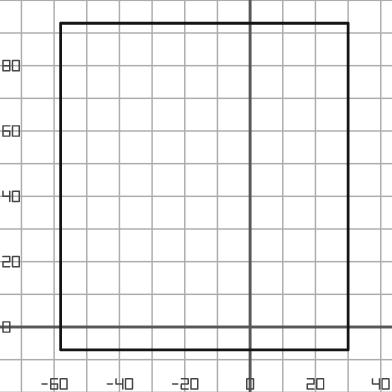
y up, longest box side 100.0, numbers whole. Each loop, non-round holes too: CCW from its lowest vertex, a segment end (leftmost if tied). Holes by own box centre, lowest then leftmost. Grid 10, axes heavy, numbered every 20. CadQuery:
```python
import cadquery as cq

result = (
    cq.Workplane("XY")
    .moveTo(-58.0, -7.0)
    .lineTo(30.0, -7.0)
    .lineTo(30.0, 93.0)
    .lineTo(-58.0, 93.0)
    .close()
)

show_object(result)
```